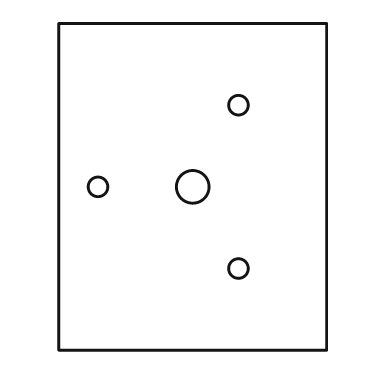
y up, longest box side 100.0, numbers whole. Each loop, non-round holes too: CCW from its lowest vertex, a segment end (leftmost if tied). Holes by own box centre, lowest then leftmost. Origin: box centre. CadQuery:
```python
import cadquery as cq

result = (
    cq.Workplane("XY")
    .moveTo(-41.0, -50.0)
    .lineTo(41.0, -50.0)
    .lineTo(41.0, 50.0)
    .lineTo(-41.0, 50.0)
    .close()
    .moveTo(14.0, -25.0)
    .circle(3.0)
    .moveTo(-29.0, 0.0)
    .circle(3.0)
    .moveTo(0.0, 0.0)
    .circle(5.0)
    .moveTo(14.0, 25.0)
    .circle(3.0)
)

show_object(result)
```